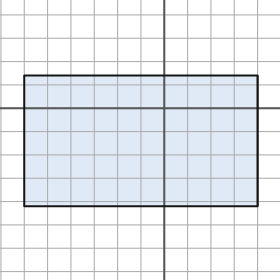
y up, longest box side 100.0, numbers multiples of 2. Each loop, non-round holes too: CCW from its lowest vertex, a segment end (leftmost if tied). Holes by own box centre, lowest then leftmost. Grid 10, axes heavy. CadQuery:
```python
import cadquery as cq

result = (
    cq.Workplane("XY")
    .moveTo(-60.0, -42.0)
    .lineTo(40.0, -42.0)
    .lineTo(40.0, 14.0)
    .lineTo(-60.0, 14.0)
    .close()
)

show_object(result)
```